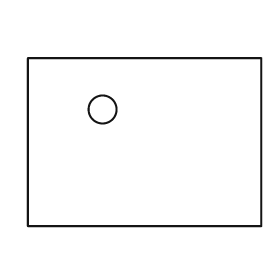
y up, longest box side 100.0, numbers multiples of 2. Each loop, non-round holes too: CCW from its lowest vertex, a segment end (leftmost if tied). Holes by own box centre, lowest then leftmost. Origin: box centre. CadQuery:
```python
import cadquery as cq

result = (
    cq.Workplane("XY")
    .moveTo(-50.0, -36.0)
    .lineTo(50.0, -36.0)
    .lineTo(50.0, 36.0)
    .lineTo(-50.0, 36.0)
    .close()
    .moveTo(-18.0, 14.0)
    .circle(6.0)
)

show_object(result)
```